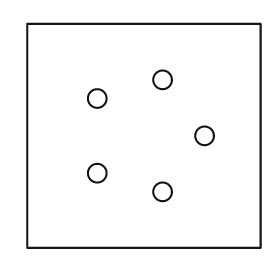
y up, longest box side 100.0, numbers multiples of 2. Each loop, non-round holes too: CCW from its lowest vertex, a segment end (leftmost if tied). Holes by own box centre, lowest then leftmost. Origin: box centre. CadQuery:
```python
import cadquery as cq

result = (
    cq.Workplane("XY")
    .moveTo(-50.0, -48.0)
    .lineTo(50.0, -48.0)
    .lineTo(50.0, 48.0)
    .lineTo(-50.0, 48.0)
    .close()
    .moveTo(8.0, -24.0)
    .circle(4.0)
    .moveTo(-20.0, -16.0)
    .circle(4.0)
    .moveTo(26.0, 0.0)
    .circle(4.0)
    .moveTo(-20.0, 16.0)
    .circle(4.0)
    .moveTo(8.0, 24.0)
    .circle(4.0)
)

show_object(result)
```